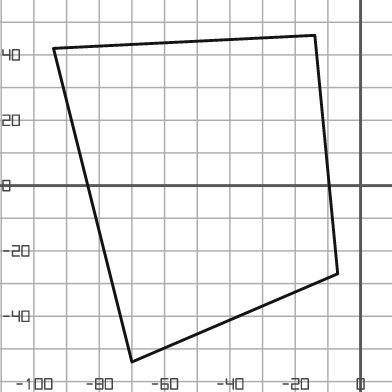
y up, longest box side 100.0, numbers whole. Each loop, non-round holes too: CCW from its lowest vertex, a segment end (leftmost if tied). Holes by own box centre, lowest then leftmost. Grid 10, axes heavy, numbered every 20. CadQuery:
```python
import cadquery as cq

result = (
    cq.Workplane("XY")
    .moveTo(-70.0, -54.0)
    .lineTo(-7.0, -27.0)
    .lineTo(-14.0, 46.0)
    .lineTo(-94.0, 42.0)
    .close()
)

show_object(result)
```